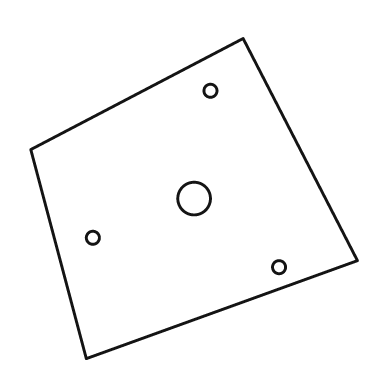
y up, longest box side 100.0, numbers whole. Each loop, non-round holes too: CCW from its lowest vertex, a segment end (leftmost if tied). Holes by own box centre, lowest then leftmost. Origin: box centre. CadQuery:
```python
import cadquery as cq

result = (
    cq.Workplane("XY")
    .moveTo(-33.0, -49.0)
    .lineTo(50.0, -19.0)
    .lineTo(15.0, 49.0)
    .lineTo(-50.0, 15.0)
    .close()
    .moveTo(26.0, -21.0)
    .circle(2.0)
    .moveTo(-31.0, -12.0)
    .circle(2.0)
    .moveTo(0.0, 0.0)
    .circle(5.0)
    .moveTo(5.0, 33.0)
    .circle(2.0)
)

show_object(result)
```